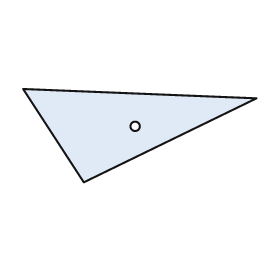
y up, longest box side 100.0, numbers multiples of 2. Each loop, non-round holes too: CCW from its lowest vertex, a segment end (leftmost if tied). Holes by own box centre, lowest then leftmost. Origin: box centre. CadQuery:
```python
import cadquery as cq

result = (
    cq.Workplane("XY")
    .moveTo(-24.0, -20.0)
    .lineTo(50.0, 16.0)
    .lineTo(-50.0, 20.0)
    .close()
    .moveTo(-2.0, 4.0)
    .circle(2.0)
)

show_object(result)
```